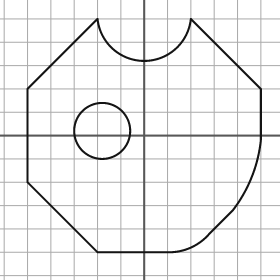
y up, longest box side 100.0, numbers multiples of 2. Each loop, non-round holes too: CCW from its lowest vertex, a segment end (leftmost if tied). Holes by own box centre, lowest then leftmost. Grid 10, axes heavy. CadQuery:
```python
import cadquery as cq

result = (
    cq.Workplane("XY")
    .moveTo(-20.0, -50.0)
    .lineTo(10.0, -50.0)
    .threePointArc((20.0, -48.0), (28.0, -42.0))
    .lineTo(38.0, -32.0)
    .threePointArc((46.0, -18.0), (50.0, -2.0))
    .lineTo(50.0, 20.0)
    .lineTo(20.0, 50.0)
    .threePointArc((0.0, 32.0), (-20.0, 50.0))
    .lineTo(-50.0, 20.0)
    .lineTo(-50.0, -20.0)
    .close()
    .moveTo(-18.0, 2.0)
    .circle(12.0)
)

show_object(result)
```